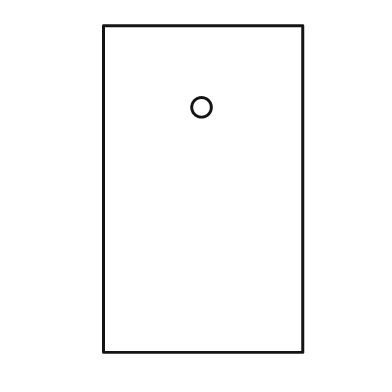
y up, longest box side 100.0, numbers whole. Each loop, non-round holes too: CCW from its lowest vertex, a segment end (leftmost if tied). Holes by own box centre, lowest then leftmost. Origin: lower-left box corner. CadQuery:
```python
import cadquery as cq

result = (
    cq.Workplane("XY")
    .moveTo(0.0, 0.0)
    .lineTo(61.0, 0.0)
    .lineTo(61.0, 100.0)
    .lineTo(0.0, 100.0)
    .close()
    .moveTo(30.0, 75.0)
    .circle(3.0)
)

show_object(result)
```